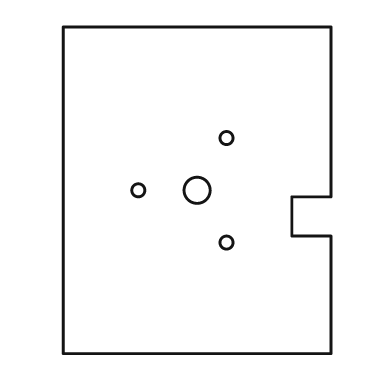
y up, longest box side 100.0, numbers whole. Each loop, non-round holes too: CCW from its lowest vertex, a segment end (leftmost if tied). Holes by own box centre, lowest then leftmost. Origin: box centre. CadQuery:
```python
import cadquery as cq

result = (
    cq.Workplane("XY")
    .moveTo(-41.0, -50.0)
    .lineTo(41.0, -50.0)
    .lineTo(41.0, -14.0)
    .lineTo(29.0, -14.0)
    .lineTo(29.0, -2.0)
    .lineTo(41.0, -2.0)
    .lineTo(41.0, 50.0)
    .lineTo(-41.0, 50.0)
    .close()
    .moveTo(9.0, -16.0)
    .circle(2.0)
    .moveTo(-18.0, 0.0)
    .circle(2.0)
    .moveTo(0.0, 0.0)
    .circle(4.0)
    .moveTo(9.0, 16.0)
    .circle(2.0)
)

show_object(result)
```